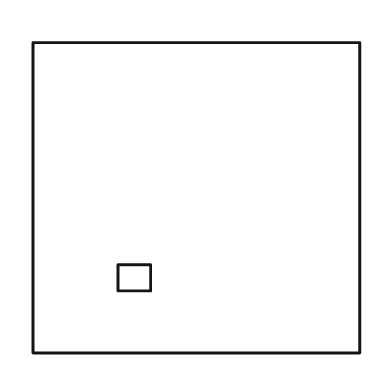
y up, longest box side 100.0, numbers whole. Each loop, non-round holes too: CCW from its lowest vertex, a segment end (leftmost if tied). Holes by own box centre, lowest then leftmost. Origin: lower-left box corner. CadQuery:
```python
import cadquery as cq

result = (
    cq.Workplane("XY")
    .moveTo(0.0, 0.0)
    .lineTo(100.0, 0.0)
    .lineTo(100.0, 95.0)
    .lineTo(0.0, 95.0)
    .close()
    .moveTo(26.0, 19.0)
    .lineTo(36.0, 19.0)
    .lineTo(36.0, 27.0)
    .lineTo(26.0, 27.0)
    .close()
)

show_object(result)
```